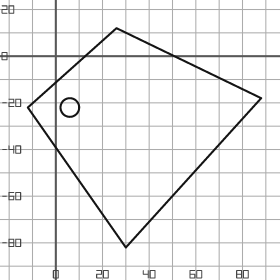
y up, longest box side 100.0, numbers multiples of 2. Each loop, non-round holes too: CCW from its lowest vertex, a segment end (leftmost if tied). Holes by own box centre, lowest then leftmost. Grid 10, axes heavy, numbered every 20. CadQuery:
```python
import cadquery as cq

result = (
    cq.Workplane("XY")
    .moveTo(30.0, -82.0)
    .lineTo(88.0, -18.0)
    .lineTo(26.0, 12.0)
    .lineTo(-12.0, -22.0)
    .close()
    .moveTo(6.0, -22.0)
    .circle(4.0)
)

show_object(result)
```